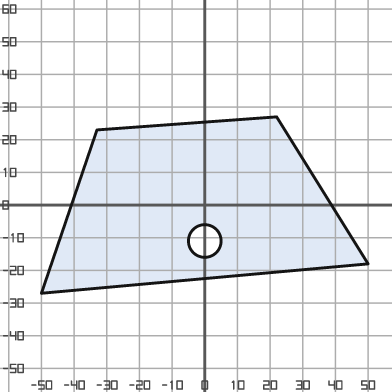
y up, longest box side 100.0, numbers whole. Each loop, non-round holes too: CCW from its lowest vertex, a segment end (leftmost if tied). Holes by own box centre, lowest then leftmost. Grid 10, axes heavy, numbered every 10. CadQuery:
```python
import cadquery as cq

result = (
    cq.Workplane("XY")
    .moveTo(-50.0, -27.0)
    .lineTo(50.0, -18.0)
    .lineTo(22.0, 27.0)
    .lineTo(-33.0, 23.0)
    .close()
    .moveTo(0.0, -11.0)
    .circle(5.0)
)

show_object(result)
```